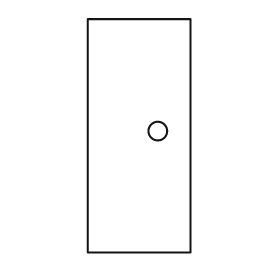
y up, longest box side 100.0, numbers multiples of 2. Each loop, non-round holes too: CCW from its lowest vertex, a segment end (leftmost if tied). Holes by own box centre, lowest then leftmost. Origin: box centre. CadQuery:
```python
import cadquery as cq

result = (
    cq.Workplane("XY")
    .moveTo(-22.0, -50.0)
    .lineTo(22.0, -50.0)
    .lineTo(22.0, 50.0)
    .lineTo(-22.0, 50.0)
    .close()
    .moveTo(8.0, 2.0)
    .circle(4.0)
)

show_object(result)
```